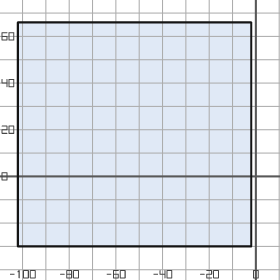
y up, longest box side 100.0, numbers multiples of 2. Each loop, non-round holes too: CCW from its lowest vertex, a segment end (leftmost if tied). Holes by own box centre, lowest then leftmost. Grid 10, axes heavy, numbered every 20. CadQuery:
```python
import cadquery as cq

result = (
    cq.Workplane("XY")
    .moveTo(-102.0, -30.0)
    .lineTo(-2.0, -30.0)
    .lineTo(-2.0, 66.0)
    .lineTo(-102.0, 66.0)
    .close()
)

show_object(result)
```